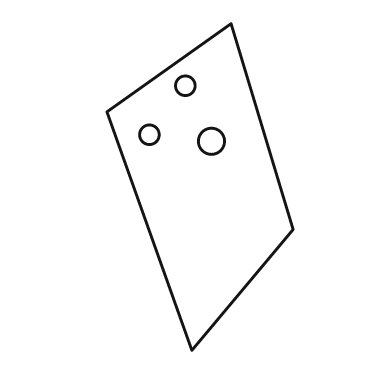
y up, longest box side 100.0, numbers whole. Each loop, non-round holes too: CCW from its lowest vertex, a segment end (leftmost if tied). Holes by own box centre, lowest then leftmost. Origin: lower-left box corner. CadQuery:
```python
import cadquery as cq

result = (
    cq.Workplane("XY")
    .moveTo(26.0, 0.0)
    .lineTo(57.0, 37.0)
    .lineTo(38.0, 100.0)
    .lineTo(0.0, 73.0)
    .close()
    .moveTo(32.0, 64.0)
    .circle(4.0)
    .moveTo(13.0, 66.0)
    .circle(3.0)
    .moveTo(24.0, 81.0)
    .circle(3.0)
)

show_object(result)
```